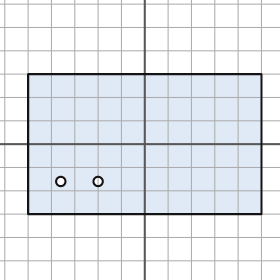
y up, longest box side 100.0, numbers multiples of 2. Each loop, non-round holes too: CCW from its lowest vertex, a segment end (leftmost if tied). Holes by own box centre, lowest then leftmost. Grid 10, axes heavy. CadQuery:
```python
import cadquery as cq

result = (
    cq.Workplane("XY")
    .moveTo(-50.0, -30.0)
    .lineTo(50.0, -30.0)
    .lineTo(50.0, 30.0)
    .lineTo(-50.0, 30.0)
    .close()
    .moveTo(-36.0, -16.0)
    .circle(2.0)
    .moveTo(-20.0, -16.0)
    .circle(2.0)
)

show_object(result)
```